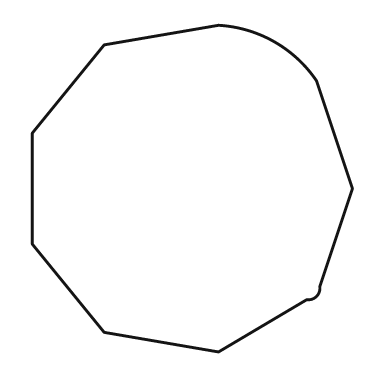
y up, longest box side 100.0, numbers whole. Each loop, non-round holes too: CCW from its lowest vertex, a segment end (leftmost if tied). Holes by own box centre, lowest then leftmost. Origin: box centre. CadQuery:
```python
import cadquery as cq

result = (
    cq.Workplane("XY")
    .moveTo(8.0, -50.0)
    .lineTo(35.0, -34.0)
    .threePointArc((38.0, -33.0), (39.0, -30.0))
    .lineTo(49.0, 0.0)
    .lineTo(38.0, 33.0)
    .threePointArc((25.0, 45.0), (8.0, 50.0))
    .lineTo(-27.0, 44.0)
    .lineTo(-49.0, 17.0)
    .lineTo(-49.0, -17.0)
    .lineTo(-27.0, -44.0)
    .close()
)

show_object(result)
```